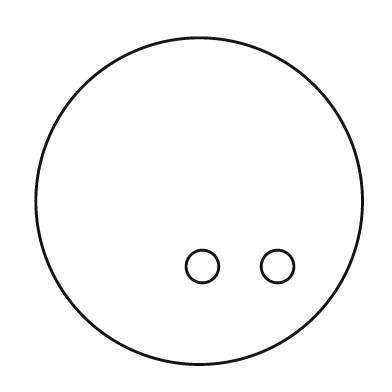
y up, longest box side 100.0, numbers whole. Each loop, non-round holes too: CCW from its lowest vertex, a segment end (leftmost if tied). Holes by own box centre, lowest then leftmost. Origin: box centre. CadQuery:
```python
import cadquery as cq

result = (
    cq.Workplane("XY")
    .moveTo(0.0, 0.0)
    .circle(50.0)
    .moveTo(1.0, -20.0)
    .circle(5.0)
    .moveTo(24.0, -20.0)
    .circle(5.0)
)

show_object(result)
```